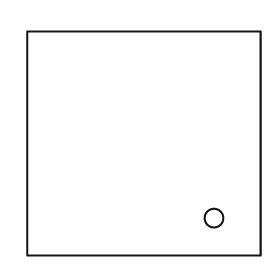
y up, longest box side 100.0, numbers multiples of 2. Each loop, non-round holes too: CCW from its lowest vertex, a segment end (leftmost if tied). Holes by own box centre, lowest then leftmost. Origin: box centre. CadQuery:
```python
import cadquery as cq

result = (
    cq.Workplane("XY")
    .moveTo(-50.0, -48.0)
    .lineTo(50.0, -48.0)
    .lineTo(50.0, 48.0)
    .lineTo(-50.0, 48.0)
    .close()
    .moveTo(30.0, -32.0)
    .circle(4.0)
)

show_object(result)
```